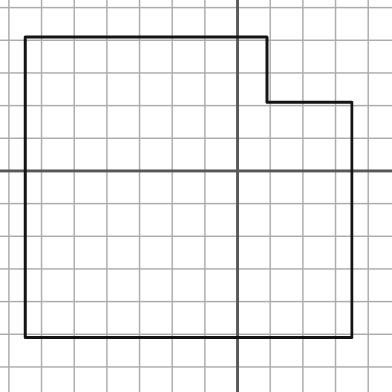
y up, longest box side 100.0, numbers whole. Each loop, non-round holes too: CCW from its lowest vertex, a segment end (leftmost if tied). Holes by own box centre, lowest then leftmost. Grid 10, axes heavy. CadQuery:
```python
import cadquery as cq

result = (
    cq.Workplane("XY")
    .moveTo(-65.0, -51.0)
    .lineTo(35.0, -51.0)
    .lineTo(35.0, 21.0)
    .lineTo(9.0, 21.0)
    .lineTo(9.0, 41.0)
    .lineTo(-65.0, 41.0)
    .close()
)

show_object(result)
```